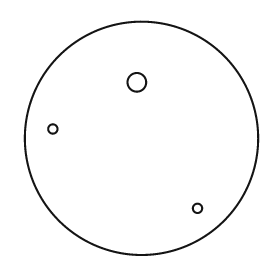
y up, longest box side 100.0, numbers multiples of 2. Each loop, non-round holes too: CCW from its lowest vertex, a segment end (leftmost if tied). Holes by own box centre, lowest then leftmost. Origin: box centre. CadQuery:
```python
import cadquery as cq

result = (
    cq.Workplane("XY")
    .moveTo(0.0, 0.0)
    .circle(50.0)
    .moveTo(24.0, -30.0)
    .circle(2.0)
    .moveTo(-38.0, 4.0)
    .circle(2.0)
    .moveTo(-2.0, 24.0)
    .circle(4.0)
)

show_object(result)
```